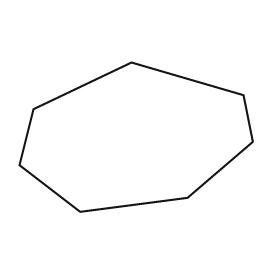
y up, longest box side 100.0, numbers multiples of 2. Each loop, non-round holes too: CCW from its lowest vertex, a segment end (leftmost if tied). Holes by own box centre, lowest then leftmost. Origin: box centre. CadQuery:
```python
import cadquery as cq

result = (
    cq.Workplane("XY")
    .moveTo(-24.0, -32.0)
    .lineTo(22.0, -26.0)
    .lineTo(50.0, -2.0)
    .lineTo(46.0, 18.0)
    .lineTo(-2.0, 32.0)
    .lineTo(-44.0, 12.0)
    .lineTo(-50.0, -12.0)
    .close()
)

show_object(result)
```